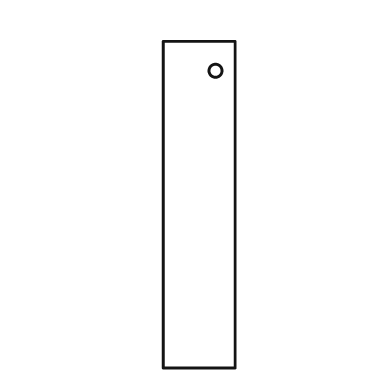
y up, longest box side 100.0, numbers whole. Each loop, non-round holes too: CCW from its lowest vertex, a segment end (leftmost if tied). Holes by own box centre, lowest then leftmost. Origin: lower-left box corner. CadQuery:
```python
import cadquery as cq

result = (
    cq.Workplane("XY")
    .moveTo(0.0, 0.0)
    .lineTo(22.0, 0.0)
    .lineTo(22.0, 100.0)
    .lineTo(0.0, 100.0)
    .close()
    .moveTo(16.0, 91.0)
    .circle(2.0)
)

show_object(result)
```